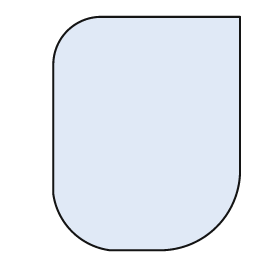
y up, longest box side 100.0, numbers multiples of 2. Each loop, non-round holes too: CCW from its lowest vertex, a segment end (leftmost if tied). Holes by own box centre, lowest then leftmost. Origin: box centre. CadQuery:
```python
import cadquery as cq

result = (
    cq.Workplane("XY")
    .moveTo(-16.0, -50.0)
    .lineTo(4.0, -50.0)
    .threePointArc((30.0, -40.0), (40.0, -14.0))
    .lineTo(40.0, 50.0)
    .lineTo(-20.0, 50.0)
    .threePointArc((-34.0, 44.0), (-40.0, 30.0))
    .lineTo(-40.0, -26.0)
    .threePointArc((-32.0, -42.0), (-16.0, -50.0))
    .close()
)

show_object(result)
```